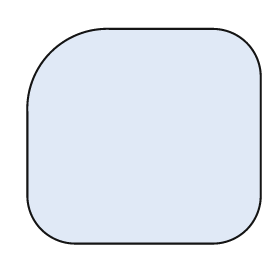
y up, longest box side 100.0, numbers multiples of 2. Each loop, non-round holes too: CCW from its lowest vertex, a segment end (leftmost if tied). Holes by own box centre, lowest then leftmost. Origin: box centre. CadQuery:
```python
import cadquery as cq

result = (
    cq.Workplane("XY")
    .moveTo(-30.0, -46.0)
    .lineTo(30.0, -46.0)
    .threePointArc((44.0, -40.0), (50.0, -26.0))
    .lineTo(50.0, 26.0)
    .threePointArc((44.0, 40.0), (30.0, 46.0))
    .lineTo(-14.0, 46.0)
    .threePointArc((-40.0, 36.0), (-50.0, 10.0))
    .lineTo(-50.0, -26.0)
    .threePointArc((-44.0, -40.0), (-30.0, -46.0))
    .close()
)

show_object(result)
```